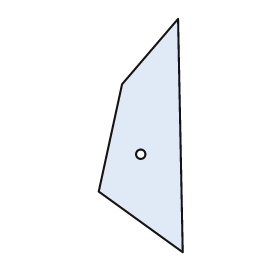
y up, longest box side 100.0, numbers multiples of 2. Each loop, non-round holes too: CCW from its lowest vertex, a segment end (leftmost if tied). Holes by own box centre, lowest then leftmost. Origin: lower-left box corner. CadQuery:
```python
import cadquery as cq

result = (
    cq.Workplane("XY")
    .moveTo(36.0, 0.0)
    .lineTo(34.0, 100.0)
    .lineTo(10.0, 72.0)
    .lineTo(0.0, 26.0)
    .close()
    .moveTo(18.0, 42.0)
    .circle(2.0)
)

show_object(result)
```